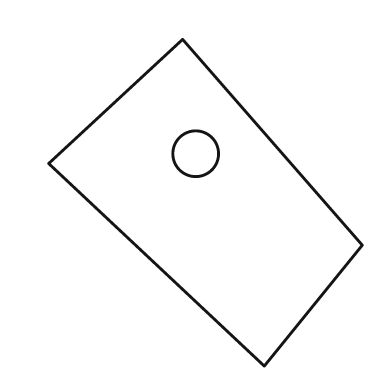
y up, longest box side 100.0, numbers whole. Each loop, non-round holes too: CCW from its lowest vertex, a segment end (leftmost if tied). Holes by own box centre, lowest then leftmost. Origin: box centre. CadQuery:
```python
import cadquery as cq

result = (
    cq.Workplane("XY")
    .moveTo(18.0, -50.0)
    .lineTo(48.0, -13.0)
    .lineTo(-7.0, 50.0)
    .lineTo(-48.0, 12.0)
    .close()
    .moveTo(-3.0, 15.0)
    .circle(7.0)
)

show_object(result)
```